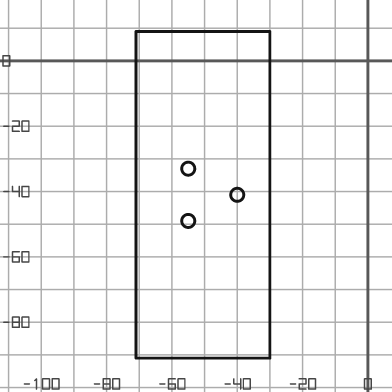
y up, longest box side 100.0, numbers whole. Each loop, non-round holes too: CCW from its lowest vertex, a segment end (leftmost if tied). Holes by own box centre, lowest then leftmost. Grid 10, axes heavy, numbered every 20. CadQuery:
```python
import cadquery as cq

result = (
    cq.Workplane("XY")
    .moveTo(-71.0, -91.0)
    .lineTo(-30.0, -91.0)
    .lineTo(-30.0, 9.0)
    .lineTo(-71.0, 9.0)
    .close()
    .moveTo(-55.0, -49.0)
    .circle(2.0)
    .moveTo(-40.0, -41.0)
    .circle(2.0)
    .moveTo(-55.0, -33.0)
    .circle(2.0)
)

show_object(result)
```